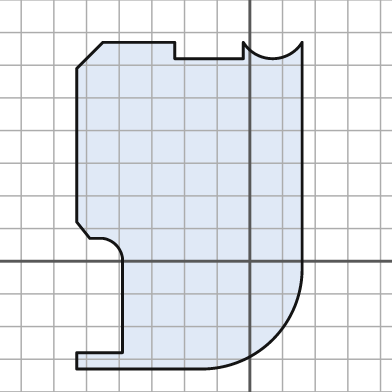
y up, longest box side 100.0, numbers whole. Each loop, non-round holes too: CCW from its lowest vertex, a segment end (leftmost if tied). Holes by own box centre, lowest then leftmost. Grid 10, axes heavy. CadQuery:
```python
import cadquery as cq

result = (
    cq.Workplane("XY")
    .moveTo(-53.0, -33.0)
    .lineTo(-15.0, -33.0)
    .threePointArc((7.0, -24.0), (16.0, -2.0))
    .lineTo(16.0, 67.0)
    .threePointArc((7.0, 62.0), (-2.0, 67.0))
    .lineTo(-2.0, 62.0)
    .lineTo(-23.0, 62.0)
    .lineTo(-23.0, 67.0)
    .lineTo(-45.0, 67.0)
    .lineTo(-53.0, 59.0)
    .lineTo(-53.0, 12.0)
    .lineTo(-49.0, 7.0)
    .lineTo(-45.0, 7.0)
    .threePointArc((-41.0, 5.0), (-39.0, 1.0))
    .lineTo(-39.0, -28.0)
    .lineTo(-53.0, -28.0)
    .close()
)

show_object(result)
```